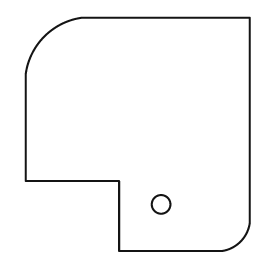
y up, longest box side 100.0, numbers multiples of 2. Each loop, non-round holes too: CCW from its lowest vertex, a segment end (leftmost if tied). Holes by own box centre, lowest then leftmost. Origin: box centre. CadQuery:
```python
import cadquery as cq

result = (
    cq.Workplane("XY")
    .moveTo(-8.0, -50.0)
    .lineTo(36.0, -50.0)
    .threePointArc((44.0, -46.0), (48.0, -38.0))
    .lineTo(48.0, 50.0)
    .lineTo(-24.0, 50.0)
    .threePointArc((-40.0, 42.0), (-48.0, 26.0))
    .lineTo(-48.0, -20.0)
    .lineTo(-8.0, -20.0)
    .close()
    .moveTo(10.0, -30.0)
    .circle(4.0)
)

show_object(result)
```